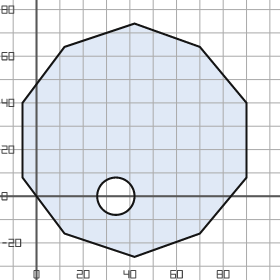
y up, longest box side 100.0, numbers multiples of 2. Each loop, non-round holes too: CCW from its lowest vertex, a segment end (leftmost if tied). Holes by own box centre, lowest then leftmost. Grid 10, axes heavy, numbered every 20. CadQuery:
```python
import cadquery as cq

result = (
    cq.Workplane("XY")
    .moveTo(42.0, -26.0)
    .lineTo(70.0, -16.0)
    .lineTo(90.0, 8.0)
    .lineTo(90.0, 40.0)
    .lineTo(70.0, 64.0)
    .lineTo(42.0, 74.0)
    .lineTo(12.0, 64.0)
    .lineTo(-6.0, 40.0)
    .lineTo(-6.0, 8.0)
    .lineTo(12.0, -16.0)
    .close()
    .moveTo(34.0, 0.0)
    .circle(8.0)
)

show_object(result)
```